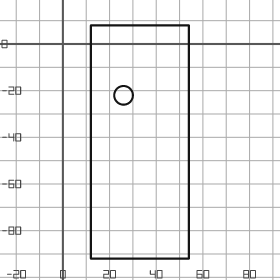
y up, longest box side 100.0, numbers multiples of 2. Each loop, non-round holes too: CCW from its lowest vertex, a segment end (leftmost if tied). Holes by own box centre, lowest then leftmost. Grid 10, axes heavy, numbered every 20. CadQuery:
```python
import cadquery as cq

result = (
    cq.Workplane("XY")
    .moveTo(12.0, -92.0)
    .lineTo(54.0, -92.0)
    .lineTo(54.0, 8.0)
    .lineTo(12.0, 8.0)
    .close()
    .moveTo(26.0, -22.0)
    .circle(4.0)
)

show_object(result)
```